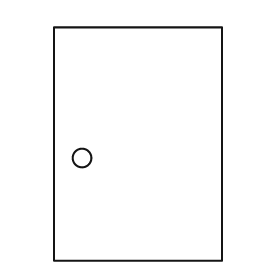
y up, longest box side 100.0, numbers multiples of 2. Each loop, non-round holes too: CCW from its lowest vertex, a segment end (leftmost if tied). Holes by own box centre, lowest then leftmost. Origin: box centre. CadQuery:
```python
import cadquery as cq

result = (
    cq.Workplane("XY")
    .moveTo(-36.0, -50.0)
    .lineTo(36.0, -50.0)
    .lineTo(36.0, 50.0)
    .lineTo(-36.0, 50.0)
    .close()
    .moveTo(-24.0, -6.0)
    .circle(4.0)
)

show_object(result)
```